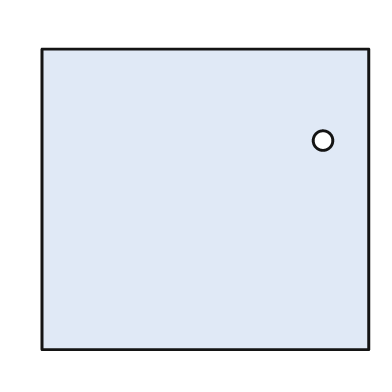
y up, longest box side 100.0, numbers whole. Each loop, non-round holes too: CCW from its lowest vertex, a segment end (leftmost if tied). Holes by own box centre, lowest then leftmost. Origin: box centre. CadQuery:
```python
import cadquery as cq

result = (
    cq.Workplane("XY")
    .moveTo(-50.0, -46.0)
    .lineTo(50.0, -46.0)
    .lineTo(50.0, 46.0)
    .lineTo(-50.0, 46.0)
    .close()
    .moveTo(36.0, 18.0)
    .circle(3.0)
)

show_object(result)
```